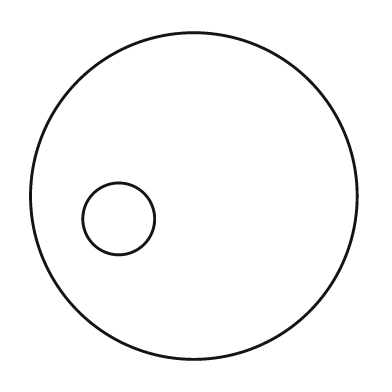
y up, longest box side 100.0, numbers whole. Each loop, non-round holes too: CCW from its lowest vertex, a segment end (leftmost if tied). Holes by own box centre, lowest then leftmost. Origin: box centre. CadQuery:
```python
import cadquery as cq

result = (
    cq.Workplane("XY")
    .moveTo(0.0, 0.0)
    .circle(50.0)
    .moveTo(-23.0, -7.0)
    .circle(11.0)
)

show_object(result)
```